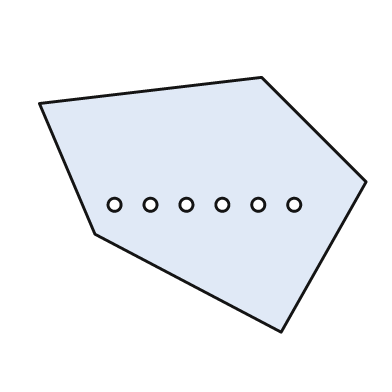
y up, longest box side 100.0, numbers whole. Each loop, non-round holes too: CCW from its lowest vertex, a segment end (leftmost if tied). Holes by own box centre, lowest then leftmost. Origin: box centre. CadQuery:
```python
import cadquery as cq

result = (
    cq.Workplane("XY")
    .moveTo(24.0, -39.0)
    .lineTo(50.0, 7.0)
    .lineTo(18.0, 39.0)
    .lineTo(-50.0, 31.0)
    .lineTo(-33.0, -9.0)
    .close()
    .moveTo(-27.0, 0.0)
    .circle(2.0)
    .moveTo(-16.0, 0.0)
    .circle(2.0)
    .moveTo(-5.0, 0.0)
    .circle(2.0)
    .moveTo(6.0, 0.0)
    .circle(2.0)
    .moveTo(17.0, 0.0)
    .circle(2.0)
    .moveTo(28.0, 0.0)
    .circle(2.0)
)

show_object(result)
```